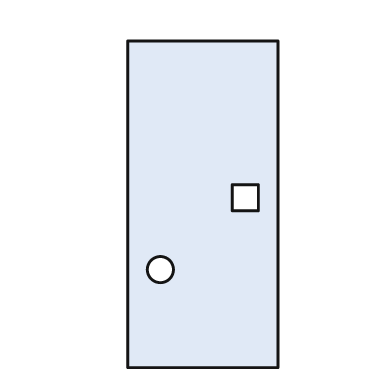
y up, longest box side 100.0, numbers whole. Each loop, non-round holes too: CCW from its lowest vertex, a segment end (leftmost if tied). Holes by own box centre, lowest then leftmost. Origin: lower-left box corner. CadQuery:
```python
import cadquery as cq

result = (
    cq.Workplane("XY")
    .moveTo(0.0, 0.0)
    .lineTo(46.0, 0.0)
    .lineTo(46.0, 100.0)
    .lineTo(0.0, 100.0)
    .close()
    .moveTo(10.0, 30.0)
    .circle(4.0)
    .moveTo(32.0, 48.0)
    .lineTo(40.0, 48.0)
    .lineTo(40.0, 56.0)
    .lineTo(32.0, 56.0)
    .close()
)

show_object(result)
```